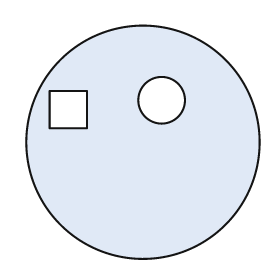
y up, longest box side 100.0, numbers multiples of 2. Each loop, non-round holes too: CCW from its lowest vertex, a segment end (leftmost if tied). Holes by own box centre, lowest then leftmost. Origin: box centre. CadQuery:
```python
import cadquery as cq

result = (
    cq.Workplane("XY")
    .moveTo(0.0, 0.0)
    .circle(50.0)
    .moveTo(-40.0, 6.0)
    .lineTo(-24.0, 6.0)
    .lineTo(-24.0, 22.0)
    .lineTo(-40.0, 22.0)
    .close()
    .moveTo(8.0, 18.0)
    .circle(10.0)
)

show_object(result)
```